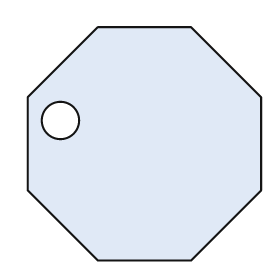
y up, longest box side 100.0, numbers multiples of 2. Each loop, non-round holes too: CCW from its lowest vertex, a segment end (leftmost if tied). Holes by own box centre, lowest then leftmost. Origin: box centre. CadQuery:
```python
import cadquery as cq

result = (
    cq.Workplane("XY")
    .moveTo(-20.0, -50.0)
    .lineTo(20.0, -50.0)
    .lineTo(50.0, -20.0)
    .lineTo(50.0, 20.0)
    .lineTo(20.0, 50.0)
    .lineTo(-20.0, 50.0)
    .lineTo(-50.0, 20.0)
    .lineTo(-50.0, -20.0)
    .close()
    .moveTo(-36.0, 10.0)
    .circle(8.0)
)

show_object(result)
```